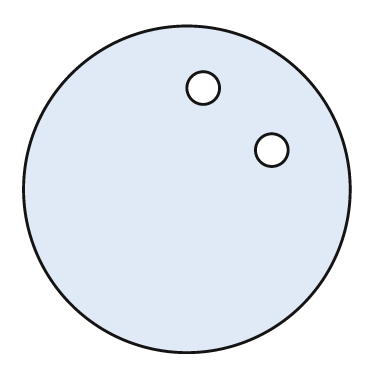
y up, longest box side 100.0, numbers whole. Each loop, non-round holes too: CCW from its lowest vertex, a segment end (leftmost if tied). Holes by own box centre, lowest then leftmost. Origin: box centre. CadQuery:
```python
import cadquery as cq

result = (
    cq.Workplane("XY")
    .moveTo(0.0, 0.0)
    .circle(50.0)
    .moveTo(26.0, 12.0)
    .circle(5.0)
    .moveTo(5.0, 31.0)
    .circle(5.0)
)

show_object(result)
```